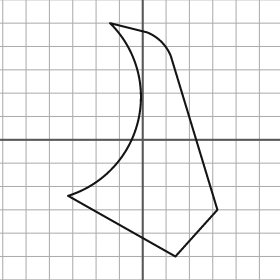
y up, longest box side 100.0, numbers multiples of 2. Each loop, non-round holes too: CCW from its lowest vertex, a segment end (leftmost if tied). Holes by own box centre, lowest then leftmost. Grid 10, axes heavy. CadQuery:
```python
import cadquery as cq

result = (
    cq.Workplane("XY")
    .moveTo(14.0, -50.0)
    .lineTo(32.0, -30.0)
    .lineTo(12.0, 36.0)
    .threePointArc((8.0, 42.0), (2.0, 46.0))
    .lineTo(-14.0, 50.0)
    .threePointArc((-2.0, 8.0), (-32.0, -24.0))
    .close()
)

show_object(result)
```